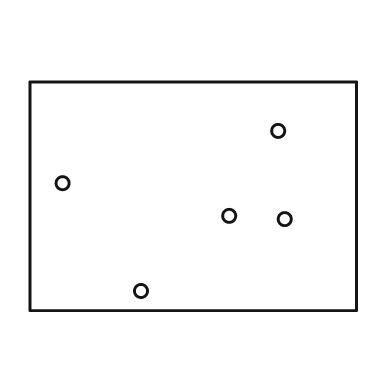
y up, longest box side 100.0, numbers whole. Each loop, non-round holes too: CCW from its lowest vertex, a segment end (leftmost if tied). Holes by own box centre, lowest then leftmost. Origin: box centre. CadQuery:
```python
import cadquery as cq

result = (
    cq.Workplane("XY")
    .moveTo(-50.0, -35.0)
    .lineTo(50.0, -35.0)
    .lineTo(50.0, 35.0)
    .lineTo(-50.0, 35.0)
    .close()
    .moveTo(-16.0, -29.0)
    .circle(2.0)
    .moveTo(28.0, -7.0)
    .circle(2.0)
    .moveTo(11.0, -6.0)
    .circle(2.0)
    .moveTo(-40.0, 4.0)
    .circle(2.0)
    .moveTo(26.0, 20.0)
    .circle(2.0)
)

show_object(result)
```